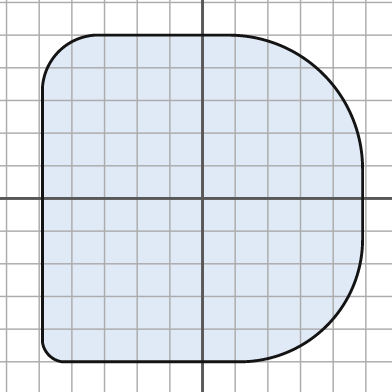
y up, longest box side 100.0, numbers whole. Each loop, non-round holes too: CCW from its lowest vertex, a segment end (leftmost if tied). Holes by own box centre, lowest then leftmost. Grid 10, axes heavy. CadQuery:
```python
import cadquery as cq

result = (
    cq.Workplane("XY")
    .moveTo(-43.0, -50.0)
    .lineTo(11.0, -50.0)
    .threePointArc((38.0, -39.0), (49.0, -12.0))
    .lineTo(49.0, 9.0)
    .threePointArc((37.0, 38.0), (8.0, 50.0))
    .lineTo(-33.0, 50.0)
    .threePointArc((-44.0, 45.0), (-49.0, 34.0))
    .lineTo(-49.0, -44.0)
    .threePointArc((-47.0, -48.0), (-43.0, -50.0))
    .close()
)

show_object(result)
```